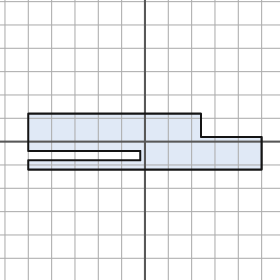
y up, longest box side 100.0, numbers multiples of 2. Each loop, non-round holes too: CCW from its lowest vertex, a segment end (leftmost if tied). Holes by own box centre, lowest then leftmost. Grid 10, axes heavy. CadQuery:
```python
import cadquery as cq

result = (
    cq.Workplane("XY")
    .moveTo(-50.0, -12.0)
    .lineTo(50.0, -12.0)
    .lineTo(50.0, 2.0)
    .lineTo(24.0, 2.0)
    .lineTo(24.0, 12.0)
    .lineTo(-50.0, 12.0)
    .lineTo(-50.0, -4.0)
    .lineTo(-2.0, -4.0)
    .lineTo(-2.0, -8.0)
    .lineTo(-50.0, -8.0)
    .close()
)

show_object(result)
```